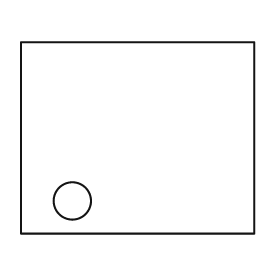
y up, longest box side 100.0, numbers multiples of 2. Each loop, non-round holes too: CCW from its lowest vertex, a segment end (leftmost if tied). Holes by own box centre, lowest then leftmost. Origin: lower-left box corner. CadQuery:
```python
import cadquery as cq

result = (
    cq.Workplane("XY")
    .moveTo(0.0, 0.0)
    .lineTo(100.0, 0.0)
    .lineTo(100.0, 82.0)
    .lineTo(0.0, 82.0)
    .close()
    .moveTo(22.0, 14.0)
    .circle(8.0)
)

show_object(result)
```